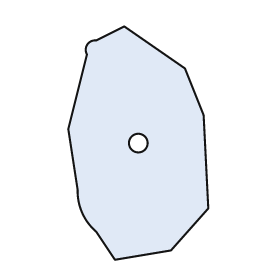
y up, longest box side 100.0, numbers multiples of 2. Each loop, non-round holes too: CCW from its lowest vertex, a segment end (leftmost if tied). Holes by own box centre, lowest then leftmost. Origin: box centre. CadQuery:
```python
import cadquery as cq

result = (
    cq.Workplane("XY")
    .moveTo(-10.0, -50.0)
    .lineTo(14.0, -46.0)
    .lineTo(30.0, -28.0)
    .lineTo(28.0, 12.0)
    .lineTo(20.0, 32.0)
    .lineTo(-6.0, 50.0)
    .lineTo(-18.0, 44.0)
    .threePointArc((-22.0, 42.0), (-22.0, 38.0))
    .lineTo(-30.0, 6.0)
    .lineTo(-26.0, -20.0)
    .threePointArc((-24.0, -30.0), (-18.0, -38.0))
    .close()
    .moveTo(0.0, 0.0)
    .circle(4.0)
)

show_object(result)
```